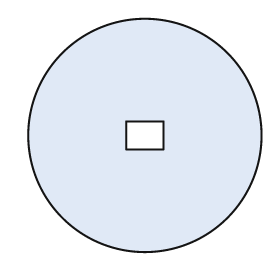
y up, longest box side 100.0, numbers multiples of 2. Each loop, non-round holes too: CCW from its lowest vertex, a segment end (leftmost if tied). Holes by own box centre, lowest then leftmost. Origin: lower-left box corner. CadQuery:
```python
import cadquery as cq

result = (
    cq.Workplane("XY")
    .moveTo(50.0, 50.0)
    .circle(50.0)
    .moveTo(42.0, 44.0)
    .lineTo(58.0, 44.0)
    .lineTo(58.0, 56.0)
    .lineTo(42.0, 56.0)
    .close()
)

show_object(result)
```